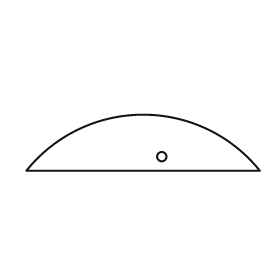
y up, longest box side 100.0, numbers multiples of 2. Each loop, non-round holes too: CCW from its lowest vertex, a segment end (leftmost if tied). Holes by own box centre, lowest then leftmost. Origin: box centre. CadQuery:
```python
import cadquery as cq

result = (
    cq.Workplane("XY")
    .moveTo(-50.0, -12.0)
    .lineTo(50.0, -12.0)
    .threePointArc((0.0, 12.0), (-50.0, -12.0))
    .close()
    .moveTo(8.0, -6.0)
    .circle(2.0)
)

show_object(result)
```